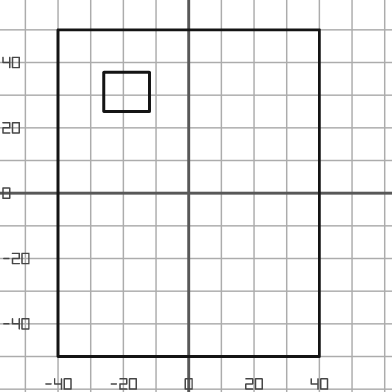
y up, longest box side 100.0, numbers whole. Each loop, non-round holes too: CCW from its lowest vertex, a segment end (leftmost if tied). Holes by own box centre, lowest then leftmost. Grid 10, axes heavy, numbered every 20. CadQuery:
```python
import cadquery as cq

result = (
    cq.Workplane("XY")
    .moveTo(-40.0, -50.0)
    .lineTo(40.0, -50.0)
    .lineTo(40.0, 50.0)
    .lineTo(-40.0, 50.0)
    .close()
    .moveTo(-26.0, 25.0)
    .lineTo(-12.0, 25.0)
    .lineTo(-12.0, 37.0)
    .lineTo(-26.0, 37.0)
    .close()
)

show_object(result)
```